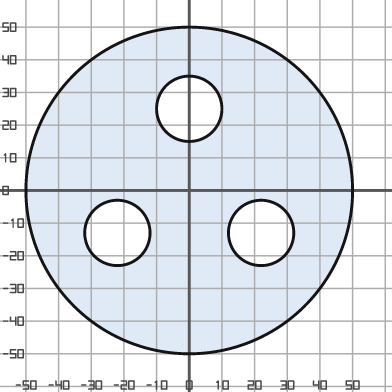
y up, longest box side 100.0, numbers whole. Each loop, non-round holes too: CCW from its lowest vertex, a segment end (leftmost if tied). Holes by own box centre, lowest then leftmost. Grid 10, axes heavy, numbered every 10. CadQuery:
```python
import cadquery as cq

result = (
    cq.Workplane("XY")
    .moveTo(0.0, 0.0)
    .circle(50.0)
    .moveTo(-22.0, -13.0)
    .circle(10.0)
    .moveTo(22.0, -13.0)
    .circle(10.0)
    .moveTo(0.0, 25.0)
    .circle(10.0)
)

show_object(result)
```